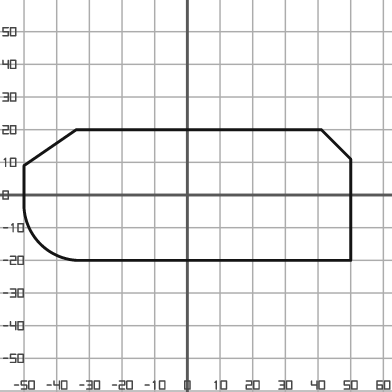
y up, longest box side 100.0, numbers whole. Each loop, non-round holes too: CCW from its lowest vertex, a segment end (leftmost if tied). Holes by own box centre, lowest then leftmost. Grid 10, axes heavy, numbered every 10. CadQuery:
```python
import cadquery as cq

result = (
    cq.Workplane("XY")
    .moveTo(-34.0, -20.0)
    .lineTo(50.0, -20.0)
    .lineTo(50.0, 11.0)
    .lineTo(41.0, 20.0)
    .lineTo(-34.0, 20.0)
    .lineTo(-50.0, 9.0)
    .lineTo(-50.0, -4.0)
    .threePointArc((-45.0, -15.0), (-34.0, -20.0))
    .close()
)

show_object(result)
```